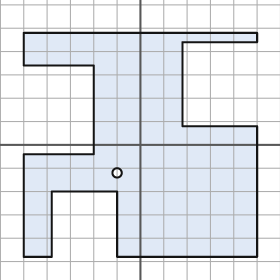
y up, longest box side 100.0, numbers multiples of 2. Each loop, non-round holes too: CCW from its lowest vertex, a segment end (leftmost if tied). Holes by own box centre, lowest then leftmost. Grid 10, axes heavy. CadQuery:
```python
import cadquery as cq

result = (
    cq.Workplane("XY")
    .moveTo(-50.0, -48.0)
    .lineTo(-38.0, -48.0)
    .lineTo(-38.0, -20.0)
    .lineTo(-10.0, -20.0)
    .lineTo(-10.0, -48.0)
    .lineTo(50.0, -48.0)
    .lineTo(50.0, 8.0)
    .lineTo(18.0, 8.0)
    .lineTo(18.0, 44.0)
    .lineTo(50.0, 44.0)
    .lineTo(50.0, 48.0)
    .lineTo(-50.0, 48.0)
    .lineTo(-50.0, 34.0)
    .lineTo(-20.0, 34.0)
    .lineTo(-20.0, -4.0)
    .lineTo(-50.0, -4.0)
    .close()
    .moveTo(-10.0, -12.0)
    .circle(2.0)
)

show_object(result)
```